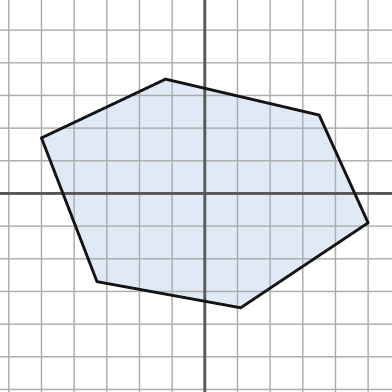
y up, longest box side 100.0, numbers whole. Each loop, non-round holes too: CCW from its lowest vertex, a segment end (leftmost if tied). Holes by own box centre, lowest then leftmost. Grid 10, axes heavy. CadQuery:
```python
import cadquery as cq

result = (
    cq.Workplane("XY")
    .moveTo(11.0, -35.0)
    .lineTo(50.0, -9.0)
    .lineTo(35.0, 24.0)
    .lineTo(-12.0, 35.0)
    .lineTo(-50.0, 17.0)
    .lineTo(-33.0, -27.0)
    .close()
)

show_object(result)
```